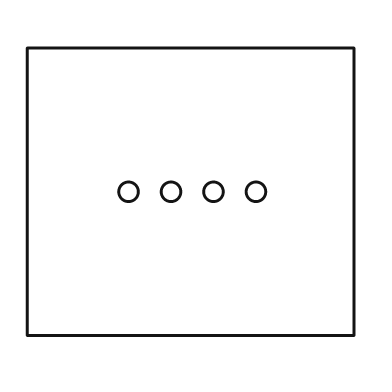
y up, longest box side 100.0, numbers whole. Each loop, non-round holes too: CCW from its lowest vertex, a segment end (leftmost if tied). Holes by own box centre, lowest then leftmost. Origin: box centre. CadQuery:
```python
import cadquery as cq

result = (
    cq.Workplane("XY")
    .moveTo(-50.0, -44.0)
    .lineTo(50.0, -44.0)
    .lineTo(50.0, 44.0)
    .lineTo(-50.0, 44.0)
    .close()
    .moveTo(-19.0, 0.0)
    .circle(3.0)
    .moveTo(-6.0, 0.0)
    .circle(3.0)
    .moveTo(7.0, 0.0)
    .circle(3.0)
    .moveTo(20.0, 0.0)
    .circle(3.0)
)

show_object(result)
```